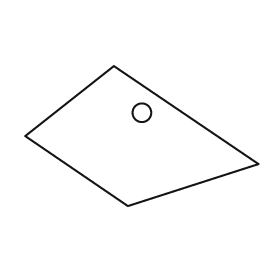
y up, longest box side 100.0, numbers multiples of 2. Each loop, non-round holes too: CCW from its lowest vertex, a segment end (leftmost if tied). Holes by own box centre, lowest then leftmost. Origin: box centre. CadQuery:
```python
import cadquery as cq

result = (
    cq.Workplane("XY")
    .moveTo(-6.0, -30.0)
    .lineTo(50.0, -12.0)
    .lineTo(-12.0, 30.0)
    .lineTo(-50.0, 0.0)
    .close()
    .moveTo(0.0, 10.0)
    .circle(4.0)
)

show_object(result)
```